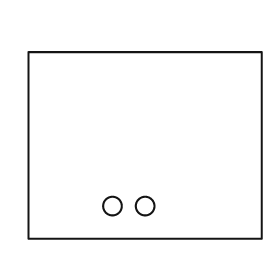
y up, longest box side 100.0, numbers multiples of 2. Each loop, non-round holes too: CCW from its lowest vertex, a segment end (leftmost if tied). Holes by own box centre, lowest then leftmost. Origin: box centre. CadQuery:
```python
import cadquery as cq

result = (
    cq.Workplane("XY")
    .moveTo(-50.0, -40.0)
    .lineTo(50.0, -40.0)
    .lineTo(50.0, 40.0)
    .lineTo(-50.0, 40.0)
    .close()
    .moveTo(-14.0, -26.0)
    .circle(4.0)
    .moveTo(0.0, -26.0)
    .circle(4.0)
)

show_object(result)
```